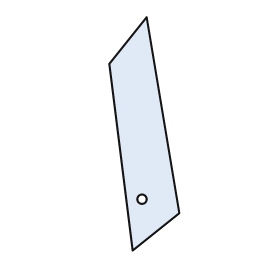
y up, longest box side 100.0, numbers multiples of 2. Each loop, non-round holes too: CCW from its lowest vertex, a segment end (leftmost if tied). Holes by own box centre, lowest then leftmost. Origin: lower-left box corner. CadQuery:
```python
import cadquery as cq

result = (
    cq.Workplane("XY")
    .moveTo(10.0, 0.0)
    .lineTo(30.0, 16.0)
    .lineTo(16.0, 100.0)
    .lineTo(0.0, 80.0)
    .close()
    .moveTo(14.0, 22.0)
    .circle(2.0)
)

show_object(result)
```